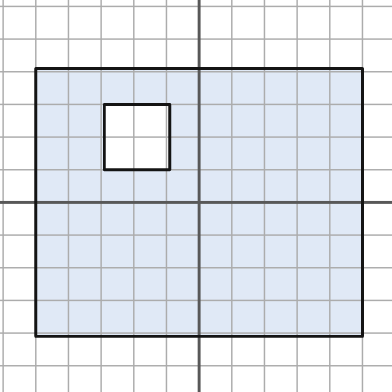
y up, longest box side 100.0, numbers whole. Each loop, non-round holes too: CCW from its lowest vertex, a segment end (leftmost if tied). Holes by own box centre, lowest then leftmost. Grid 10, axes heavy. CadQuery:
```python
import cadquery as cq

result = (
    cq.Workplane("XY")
    .moveTo(-50.0, -41.0)
    .lineTo(50.0, -41.0)
    .lineTo(50.0, 41.0)
    .lineTo(-50.0, 41.0)
    .close()
    .moveTo(-29.0, 10.0)
    .lineTo(-9.0, 10.0)
    .lineTo(-9.0, 30.0)
    .lineTo(-29.0, 30.0)
    .close()
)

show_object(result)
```